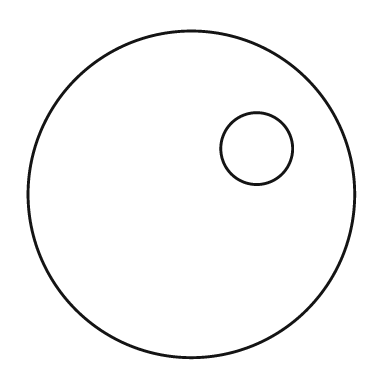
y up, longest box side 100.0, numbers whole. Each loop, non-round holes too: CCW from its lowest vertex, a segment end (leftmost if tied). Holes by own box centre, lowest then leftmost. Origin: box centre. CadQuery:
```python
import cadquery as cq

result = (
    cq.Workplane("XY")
    .moveTo(0.0, 0.0)
    .circle(50.0)
    .moveTo(20.0, 14.0)
    .circle(11.0)
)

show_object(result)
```